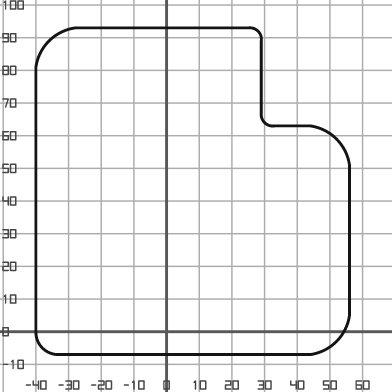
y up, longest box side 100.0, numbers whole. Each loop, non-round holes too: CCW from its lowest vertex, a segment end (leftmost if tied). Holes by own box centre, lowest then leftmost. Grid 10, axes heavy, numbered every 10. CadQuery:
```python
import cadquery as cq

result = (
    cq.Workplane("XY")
    .moveTo(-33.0, -7.0)
    .lineTo(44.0, -7.0)
    .threePointArc((52.0, -3.0), (56.0, 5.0))
    .lineTo(56.0, 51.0)
    .threePointArc((52.0, 59.0), (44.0, 63.0))
    .lineTo(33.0, 63.0)
    .threePointArc((30.0, 64.0), (29.0, 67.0))
    .lineTo(29.0, 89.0)
    .threePointArc((28.0, 92.0), (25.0, 93.0))
    .lineTo(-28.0, 93.0)
    .threePointArc((-36.0, 89.0), (-40.0, 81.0))
    .lineTo(-40.0, 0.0)
    .threePointArc((-38.0, -5.0), (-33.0, -7.0))
    .close()
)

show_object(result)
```